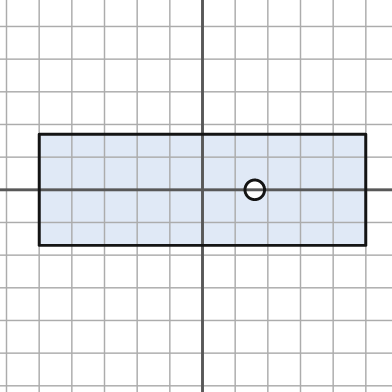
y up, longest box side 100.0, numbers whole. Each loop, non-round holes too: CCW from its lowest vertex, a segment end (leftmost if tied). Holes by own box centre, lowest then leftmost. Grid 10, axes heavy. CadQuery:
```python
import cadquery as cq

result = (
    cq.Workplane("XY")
    .moveTo(-50.0, -17.0)
    .lineTo(50.0, -17.0)
    .lineTo(50.0, 17.0)
    .lineTo(-50.0, 17.0)
    .close()
    .moveTo(16.0, 0.0)
    .circle(3.0)
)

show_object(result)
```